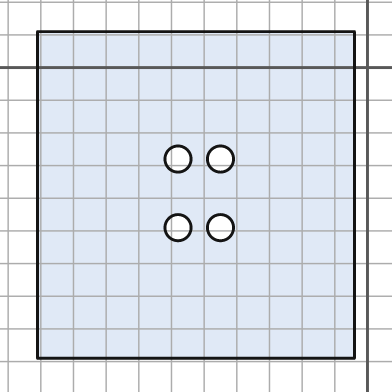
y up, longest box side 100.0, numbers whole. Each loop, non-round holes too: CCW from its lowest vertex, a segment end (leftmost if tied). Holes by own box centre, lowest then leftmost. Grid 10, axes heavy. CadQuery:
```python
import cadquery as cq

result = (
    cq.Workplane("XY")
    .moveTo(-101.0, -89.0)
    .lineTo(-4.0, -89.0)
    .lineTo(-4.0, 11.0)
    .lineTo(-101.0, 11.0)
    .close()
    .moveTo(-58.0, -49.0)
    .circle(4.0)
    .moveTo(-45.0, -49.0)
    .circle(4.0)
    .moveTo(-58.0, -28.0)
    .circle(4.0)
    .moveTo(-45.0, -28.0)
    .circle(4.0)
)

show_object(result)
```